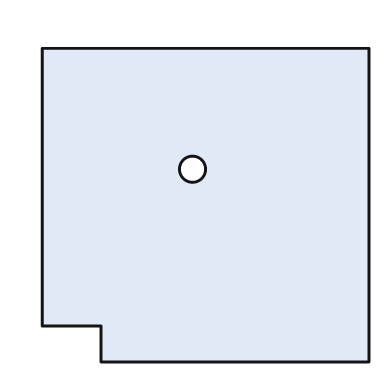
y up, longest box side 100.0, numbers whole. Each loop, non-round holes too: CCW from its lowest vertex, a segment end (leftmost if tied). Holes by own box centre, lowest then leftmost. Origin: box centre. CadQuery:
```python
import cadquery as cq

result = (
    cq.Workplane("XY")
    .moveTo(-32.0, -48.0)
    .lineTo(50.0, -48.0)
    .lineTo(50.0, 48.0)
    .lineTo(-50.0, 48.0)
    .lineTo(-50.0, -37.0)
    .lineTo(-32.0, -37.0)
    .close()
    .moveTo(-4.0, 11.0)
    .circle(4.0)
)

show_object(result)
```